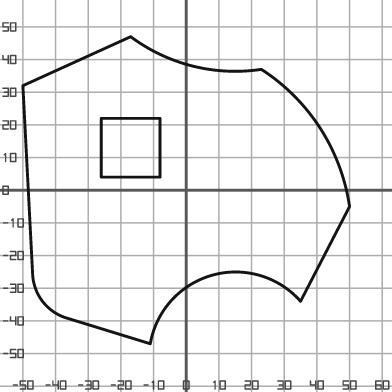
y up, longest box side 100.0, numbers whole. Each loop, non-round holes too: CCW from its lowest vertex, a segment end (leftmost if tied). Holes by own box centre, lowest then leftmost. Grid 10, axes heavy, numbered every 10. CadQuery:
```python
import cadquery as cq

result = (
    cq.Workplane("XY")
    .moveTo(-11.0, -47.0)
    .threePointArc((8.0, -26.0), (35.0, -34.0))
    .lineTo(50.0, -5.0)
    .threePointArc((41.0, 19.0), (23.0, 37.0))
    .threePointArc((2.0, 38.0), (-17.0, 47.0))
    .lineTo(-50.0, 32.0)
    .lineTo(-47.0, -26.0)
    .threePointArc((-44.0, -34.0), (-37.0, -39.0))
    .close()
    .moveTo(-26.0, 4.0)
    .lineTo(-8.0, 4.0)
    .lineTo(-8.0, 22.0)
    .lineTo(-26.0, 22.0)
    .close()
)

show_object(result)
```